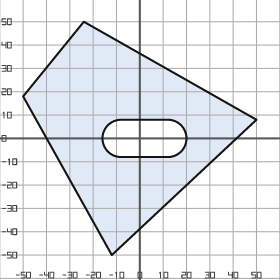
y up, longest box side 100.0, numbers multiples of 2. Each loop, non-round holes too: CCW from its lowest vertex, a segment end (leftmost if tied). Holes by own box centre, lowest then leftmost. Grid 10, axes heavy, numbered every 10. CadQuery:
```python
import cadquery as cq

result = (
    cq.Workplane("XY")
    .moveTo(-12.0, -50.0)
    .lineTo(50.0, 8.0)
    .lineTo(-24.0, 50.0)
    .lineTo(-50.0, 18.0)
    .close()
    .moveTo(-8.0, -8.0)
    .lineTo(12.0, -8.0)
    .threePointArc((20.0, 0.0), (12.0, 8.0))
    .lineTo(-8.0, 8.0)
    .threePointArc((-16.0, 0.0), (-8.0, -8.0))
    .close()
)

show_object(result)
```